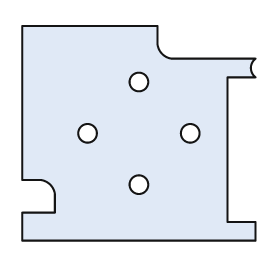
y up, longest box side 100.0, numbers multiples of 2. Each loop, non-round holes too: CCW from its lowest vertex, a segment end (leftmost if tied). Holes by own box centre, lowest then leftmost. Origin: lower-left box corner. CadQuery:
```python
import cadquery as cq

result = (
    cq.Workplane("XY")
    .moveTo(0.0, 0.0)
    .lineTo(100.0, 0.0)
    .lineTo(100.0, 8.0)
    .lineTo(88.0, 8.0)
    .lineTo(88.0, 70.0)
    .lineTo(100.0, 70.0)
    .threePointArc((98.0, 74.0), (100.0, 78.0))
    .lineTo(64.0, 78.0)
    .threePointArc((60.0, 80.0), (58.0, 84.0))
    .lineTo(58.0, 92.0)
    .lineTo(0.0, 92.0)
    .lineTo(0.0, 26.0)
    .lineTo(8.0, 26.0)
    .threePointArc((12.0, 24.0), (14.0, 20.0))
    .lineTo(14.0, 12.0)
    .lineTo(0.0, 12.0)
    .close()
    .moveTo(50.0, 24.0)
    .circle(4.0)
    .moveTo(28.0, 46.0)
    .circle(4.0)
    .moveTo(72.0, 46.0)
    .circle(4.0)
    .moveTo(50.0, 68.0)
    .circle(4.0)
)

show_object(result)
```